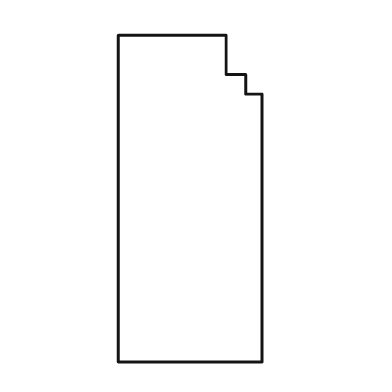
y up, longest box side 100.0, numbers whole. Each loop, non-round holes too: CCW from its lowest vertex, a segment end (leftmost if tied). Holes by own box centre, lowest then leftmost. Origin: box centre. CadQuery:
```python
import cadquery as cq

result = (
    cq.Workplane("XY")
    .moveTo(-22.0, -50.0)
    .lineTo(22.0, -50.0)
    .lineTo(22.0, 32.0)
    .lineTo(17.0, 32.0)
    .lineTo(17.0, 38.0)
    .lineTo(11.0, 38.0)
    .lineTo(11.0, 50.0)
    .lineTo(-22.0, 50.0)
    .close()
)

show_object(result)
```